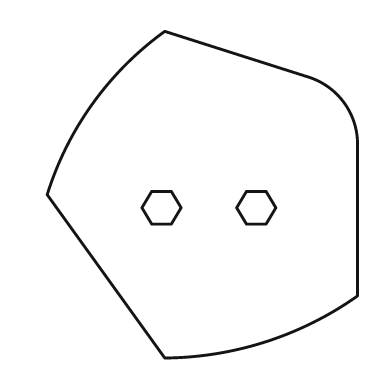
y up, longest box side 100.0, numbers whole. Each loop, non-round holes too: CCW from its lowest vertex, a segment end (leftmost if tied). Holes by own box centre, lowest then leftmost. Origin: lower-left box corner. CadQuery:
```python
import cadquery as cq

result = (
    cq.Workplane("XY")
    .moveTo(36.0, 0.0)
    .threePointArc((67.0, 5.0), (95.0, 19.0))
    .lineTo(95.0, 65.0)
    .threePointArc((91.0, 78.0), (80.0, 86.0))
    .lineTo(36.0, 100.0)
    .threePointArc((14.0, 78.0), (0.0, 50.0))
    .close()
    .moveTo(32.0, 41.0)
    .lineTo(38.0, 41.0)
    .lineTo(41.0, 46.0)
    .lineTo(38.0, 51.0)
    .lineTo(32.0, 51.0)
    .lineTo(29.0, 46.0)
    .close()
    .moveTo(61.0, 41.0)
    .lineTo(67.0, 41.0)
    .lineTo(70.0, 46.0)
    .lineTo(67.0, 51.0)
    .lineTo(61.0, 51.0)
    .lineTo(58.0, 46.0)
    .close()
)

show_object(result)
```